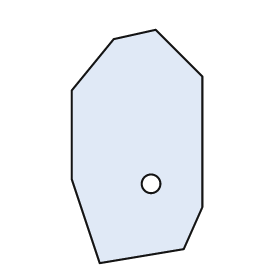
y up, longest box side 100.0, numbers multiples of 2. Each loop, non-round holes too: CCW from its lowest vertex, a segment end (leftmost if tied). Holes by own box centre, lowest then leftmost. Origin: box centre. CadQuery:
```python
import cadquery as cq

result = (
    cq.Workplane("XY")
    .moveTo(-16.0, -50.0)
    .lineTo(20.0, -44.0)
    .lineTo(28.0, -26.0)
    .lineTo(28.0, 30.0)
    .lineTo(8.0, 50.0)
    .lineTo(-10.0, 46.0)
    .lineTo(-28.0, 24.0)
    .lineTo(-28.0, -14.0)
    .close()
    .moveTo(6.0, -16.0)
    .circle(4.0)
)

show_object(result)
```